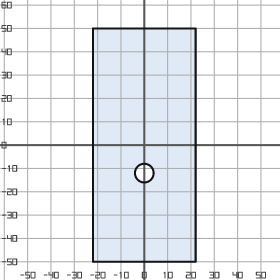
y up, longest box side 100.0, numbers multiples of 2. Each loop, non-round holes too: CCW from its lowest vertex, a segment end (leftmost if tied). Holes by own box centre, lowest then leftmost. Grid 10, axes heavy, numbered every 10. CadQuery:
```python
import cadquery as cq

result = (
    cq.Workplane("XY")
    .moveTo(-22.0, -50.0)
    .lineTo(22.0, -50.0)
    .lineTo(22.0, 50.0)
    .lineTo(-22.0, 50.0)
    .close()
    .moveTo(0.0, -12.0)
    .circle(4.0)
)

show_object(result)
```